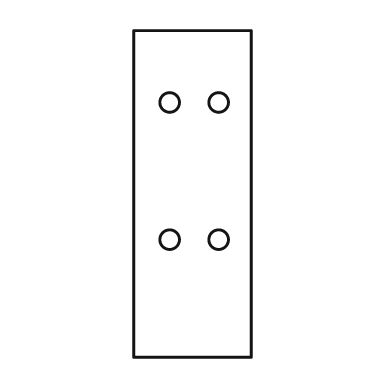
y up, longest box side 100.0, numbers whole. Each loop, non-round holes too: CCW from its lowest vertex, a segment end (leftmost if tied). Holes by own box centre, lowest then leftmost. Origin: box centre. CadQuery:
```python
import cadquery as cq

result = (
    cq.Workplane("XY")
    .moveTo(-18.0, -50.0)
    .lineTo(18.0, -50.0)
    .lineTo(18.0, 50.0)
    .lineTo(-18.0, 50.0)
    .close()
    .moveTo(-7.0, -14.0)
    .circle(3.0)
    .moveTo(8.0, -14.0)
    .circle(3.0)
    .moveTo(-7.0, 28.0)
    .circle(3.0)
    .moveTo(8.0, 28.0)
    .circle(3.0)
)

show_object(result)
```